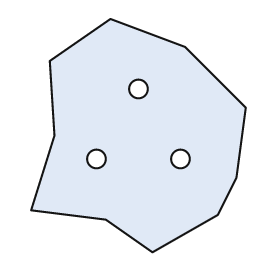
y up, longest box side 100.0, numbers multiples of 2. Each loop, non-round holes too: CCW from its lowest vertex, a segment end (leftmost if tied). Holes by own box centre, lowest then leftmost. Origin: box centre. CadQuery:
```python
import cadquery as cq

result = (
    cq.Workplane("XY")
    .moveTo(6.0, -50.0)
    .lineTo(34.0, -34.0)
    .lineTo(42.0, -18.0)
    .lineTo(46.0, 12.0)
    .lineTo(20.0, 38.0)
    .lineTo(-12.0, 50.0)
    .lineTo(-38.0, 32.0)
    .lineTo(-36.0, 0.0)
    .lineTo(-46.0, -32.0)
    .lineTo(-14.0, -36.0)
    .close()
    .moveTo(-18.0, -10.0)
    .circle(4.0)
    .moveTo(18.0, -10.0)
    .circle(4.0)
    .moveTo(0.0, 20.0)
    .circle(4.0)
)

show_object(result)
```